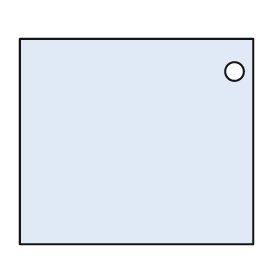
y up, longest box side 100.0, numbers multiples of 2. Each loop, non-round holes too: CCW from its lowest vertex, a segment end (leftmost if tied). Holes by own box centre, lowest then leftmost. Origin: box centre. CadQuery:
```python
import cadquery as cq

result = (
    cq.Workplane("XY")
    .moveTo(-50.0, -44.0)
    .lineTo(50.0, -44.0)
    .lineTo(50.0, 44.0)
    .lineTo(-50.0, 44.0)
    .close()
    .moveTo(42.0, 30.0)
    .circle(4.0)
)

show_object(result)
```